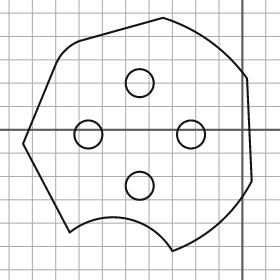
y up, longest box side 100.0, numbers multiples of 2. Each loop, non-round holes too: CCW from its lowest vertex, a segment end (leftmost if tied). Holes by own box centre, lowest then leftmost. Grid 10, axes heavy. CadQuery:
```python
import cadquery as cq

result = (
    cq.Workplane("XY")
    .moveTo(-30.0, -52.0)
    .threePointArc((-10.0, -40.0), (4.0, -22.0))
    .lineTo(2.0, 22.0)
    .threePointArc((-14.0, 38.0), (-34.0, 48.0))
    .lineTo(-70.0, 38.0)
    .threePointArc((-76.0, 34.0), (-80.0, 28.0))
    .lineTo(-94.0, -6.0)
    .lineTo(-74.0, -44.0)
    .threePointArc((-50.0, -38.0), (-30.0, -52.0))
    .close()
    .moveTo(-44.0, -24.0)
    .circle(6.0)
    .moveTo(-66.0, -2.0)
    .circle(6.0)
    .moveTo(-22.0, -2.0)
    .circle(6.0)
    .moveTo(-44.0, 20.0)
    .circle(6.0)
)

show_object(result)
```